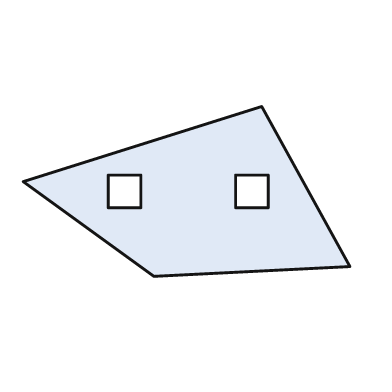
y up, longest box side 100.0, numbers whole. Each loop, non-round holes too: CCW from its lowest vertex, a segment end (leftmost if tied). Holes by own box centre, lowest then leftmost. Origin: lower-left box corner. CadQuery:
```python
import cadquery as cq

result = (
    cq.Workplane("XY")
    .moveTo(40.0, 0.0)
    .lineTo(100.0, 3.0)
    .lineTo(73.0, 52.0)
    .lineTo(0.0, 29.0)
    .close()
    .moveTo(26.0, 21.0)
    .lineTo(36.0, 21.0)
    .lineTo(36.0, 31.0)
    .lineTo(26.0, 31.0)
    .close()
    .moveTo(65.0, 21.0)
    .lineTo(75.0, 21.0)
    .lineTo(75.0, 31.0)
    .lineTo(65.0, 31.0)
    .close()
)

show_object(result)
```